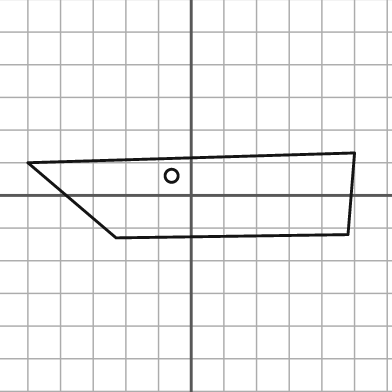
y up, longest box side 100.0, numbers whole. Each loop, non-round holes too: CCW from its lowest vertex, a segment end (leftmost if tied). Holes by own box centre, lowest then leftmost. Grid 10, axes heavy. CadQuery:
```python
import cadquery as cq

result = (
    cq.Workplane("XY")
    .moveTo(-23.0, -13.0)
    .lineTo(48.0, -12.0)
    .lineTo(50.0, 13.0)
    .lineTo(-50.0, 10.0)
    .close()
    .moveTo(-6.0, 6.0)
    .circle(2.0)
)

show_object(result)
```